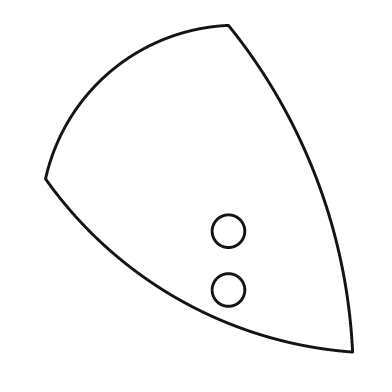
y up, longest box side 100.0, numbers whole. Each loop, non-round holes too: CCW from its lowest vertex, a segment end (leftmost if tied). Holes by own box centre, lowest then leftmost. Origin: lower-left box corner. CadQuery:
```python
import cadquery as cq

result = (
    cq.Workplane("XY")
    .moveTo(94.0, 0.0)
    .threePointArc((83.0, 53.0), (56.0, 100.0))
    .threePointArc((20.0, 86.0), (0.0, 53.0))
    .threePointArc((41.0, 16.0), (94.0, 0.0))
    .close()
    .moveTo(56.0, 19.0)
    .circle(5.0)
    .moveTo(56.0, 37.0)
    .circle(5.0)
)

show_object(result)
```